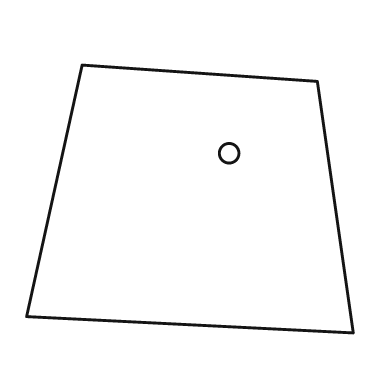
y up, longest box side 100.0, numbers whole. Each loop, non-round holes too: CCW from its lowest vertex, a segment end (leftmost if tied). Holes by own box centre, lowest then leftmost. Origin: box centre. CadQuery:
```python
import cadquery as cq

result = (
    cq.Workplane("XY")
    .moveTo(50.0, -41.0)
    .lineTo(39.0, 36.0)
    .lineTo(-33.0, 41.0)
    .lineTo(-50.0, -36.0)
    .close()
    .moveTo(12.0, 14.0)
    .circle(3.0)
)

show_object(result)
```